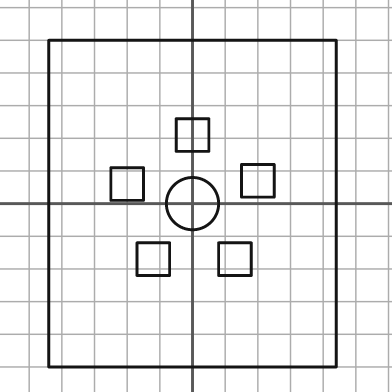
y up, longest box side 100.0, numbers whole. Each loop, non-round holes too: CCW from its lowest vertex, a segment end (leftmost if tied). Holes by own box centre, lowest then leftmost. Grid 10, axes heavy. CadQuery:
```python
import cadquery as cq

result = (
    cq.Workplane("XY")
    .moveTo(-44.0, -50.0)
    .lineTo(44.0, -50.0)
    .lineTo(44.0, 50.0)
    .lineTo(-44.0, 50.0)
    .close()
    .moveTo(-17.0, -22.0)
    .lineTo(-7.0, -22.0)
    .lineTo(-7.0, -12.0)
    .lineTo(-17.0, -12.0)
    .close()
    .moveTo(8.0, -22.0)
    .lineTo(18.0, -22.0)
    .lineTo(18.0, -12.0)
    .lineTo(8.0, -12.0)
    .close()
    .moveTo(0.0, 0.0)
    .circle(8.0)
    .moveTo(-25.0, 1.0)
    .lineTo(-15.0, 1.0)
    .lineTo(-15.0, 11.0)
    .lineTo(-25.0, 11.0)
    .close()
    .moveTo(15.0, 2.0)
    .lineTo(25.0, 2.0)
    .lineTo(25.0, 12.0)
    .lineTo(15.0, 12.0)
    .close()
    .moveTo(-5.0, 16.0)
    .lineTo(5.0, 16.0)
    .lineTo(5.0, 26.0)
    .lineTo(-5.0, 26.0)
    .close()
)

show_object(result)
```